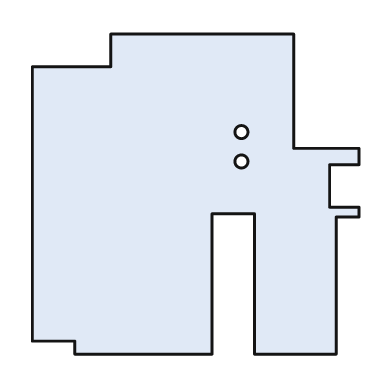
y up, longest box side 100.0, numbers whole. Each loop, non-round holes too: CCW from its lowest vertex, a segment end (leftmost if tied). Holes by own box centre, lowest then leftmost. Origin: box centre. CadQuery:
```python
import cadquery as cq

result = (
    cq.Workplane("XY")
    .moveTo(-37.0, -49.0)
    .lineTo(5.0, -49.0)
    .lineTo(5.0, -6.0)
    .lineTo(18.0, -6.0)
    .lineTo(18.0, -49.0)
    .lineTo(43.0, -49.0)
    .lineTo(43.0, -7.0)
    .lineTo(50.0, -7.0)
    .lineTo(50.0, -4.0)
    .lineTo(41.0, -4.0)
    .lineTo(41.0, 9.0)
    .lineTo(50.0, 9.0)
    .lineTo(50.0, 14.0)
    .lineTo(30.0, 14.0)
    .lineTo(30.0, 49.0)
    .lineTo(-26.0, 49.0)
    .lineTo(-26.0, 39.0)
    .lineTo(-50.0, 39.0)
    .lineTo(-50.0, -45.0)
    .lineTo(-37.0, -45.0)
    .close()
    .moveTo(14.0, 10.0)
    .circle(2.0)
    .moveTo(14.0, 19.0)
    .circle(2.0)
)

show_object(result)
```